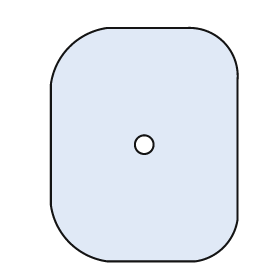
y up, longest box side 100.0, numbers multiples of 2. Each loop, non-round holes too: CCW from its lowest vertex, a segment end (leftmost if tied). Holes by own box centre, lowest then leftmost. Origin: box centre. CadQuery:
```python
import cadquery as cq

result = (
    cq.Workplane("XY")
    .moveTo(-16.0, -50.0)
    .lineTo(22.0, -50.0)
    .threePointArc((34.0, -44.0), (40.0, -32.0))
    .lineTo(40.0, 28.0)
    .threePointArc((34.0, 44.0), (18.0, 50.0))
    .lineTo(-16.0, 50.0)
    .threePointArc((-32.0, 42.0), (-40.0, 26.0))
    .lineTo(-40.0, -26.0)
    .threePointArc((-32.0, -42.0), (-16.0, -50.0))
    .close()
    .moveTo(0.0, 0.0)
    .circle(4.0)
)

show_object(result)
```